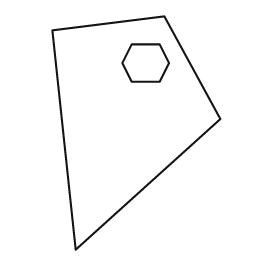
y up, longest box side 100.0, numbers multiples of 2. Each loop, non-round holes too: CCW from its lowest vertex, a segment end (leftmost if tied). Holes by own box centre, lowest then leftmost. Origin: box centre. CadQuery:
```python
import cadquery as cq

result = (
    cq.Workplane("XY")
    .moveTo(-26.0, -50.0)
    .lineTo(36.0, 6.0)
    .lineTo(12.0, 50.0)
    .lineTo(-36.0, 44.0)
    .close()
    .moveTo(-2.0, 22.0)
    .lineTo(10.0, 22.0)
    .lineTo(14.0, 30.0)
    .lineTo(10.0, 38.0)
    .lineTo(-2.0, 38.0)
    .lineTo(-6.0, 30.0)
    .close()
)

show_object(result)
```